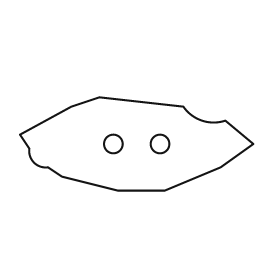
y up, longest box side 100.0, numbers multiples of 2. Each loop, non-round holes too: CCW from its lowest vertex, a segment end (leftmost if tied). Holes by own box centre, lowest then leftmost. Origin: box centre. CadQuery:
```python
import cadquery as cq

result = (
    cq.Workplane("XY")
    .moveTo(-8.0, -20.0)
    .lineTo(12.0, -20.0)
    .lineTo(36.0, -10.0)
    .lineTo(50.0, 0.0)
    .lineTo(38.0, 10.0)
    .threePointArc((28.0, 10.0), (20.0, 16.0))
    .lineTo(-16.0, 20.0)
    .lineTo(-28.0, 16.0)
    .lineTo(-50.0, 4.0)
    .lineTo(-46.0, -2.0)
    .threePointArc((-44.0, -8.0), (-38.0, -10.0))
    .lineTo(-32.0, -14.0)
    .close()
    .moveTo(-10.0, 0.0)
    .circle(4.0)
    .moveTo(10.0, 0.0)
    .circle(4.0)
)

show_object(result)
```